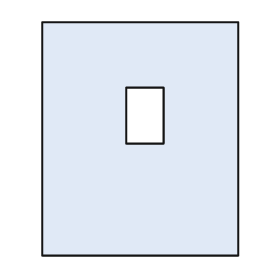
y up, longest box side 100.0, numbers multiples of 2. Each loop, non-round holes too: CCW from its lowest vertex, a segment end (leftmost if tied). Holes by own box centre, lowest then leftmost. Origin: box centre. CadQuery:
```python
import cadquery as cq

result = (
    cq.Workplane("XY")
    .moveTo(-42.0, -50.0)
    .lineTo(42.0, -50.0)
    .lineTo(42.0, 50.0)
    .lineTo(-42.0, 50.0)
    .close()
    .moveTo(-6.0, -2.0)
    .lineTo(10.0, -2.0)
    .lineTo(10.0, 22.0)
    .lineTo(-6.0, 22.0)
    .close()
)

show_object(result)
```